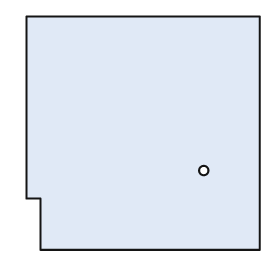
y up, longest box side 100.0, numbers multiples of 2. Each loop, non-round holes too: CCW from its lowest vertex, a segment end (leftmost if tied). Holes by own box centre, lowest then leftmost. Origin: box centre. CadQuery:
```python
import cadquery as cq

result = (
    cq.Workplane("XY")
    .moveTo(-44.0, -50.0)
    .lineTo(50.0, -50.0)
    .lineTo(50.0, 50.0)
    .lineTo(-50.0, 50.0)
    .lineTo(-50.0, -28.0)
    .lineTo(-44.0, -28.0)
    .close()
    .moveTo(26.0, -16.0)
    .circle(2.0)
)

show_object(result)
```